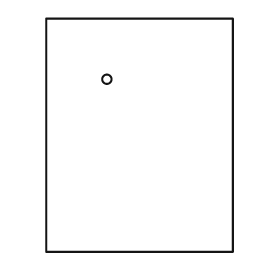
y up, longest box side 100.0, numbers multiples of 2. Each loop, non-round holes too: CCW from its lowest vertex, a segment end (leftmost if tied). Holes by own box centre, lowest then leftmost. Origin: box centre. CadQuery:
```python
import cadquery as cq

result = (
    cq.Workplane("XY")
    .moveTo(-40.0, -50.0)
    .lineTo(40.0, -50.0)
    .lineTo(40.0, 50.0)
    .lineTo(-40.0, 50.0)
    .close()
    .moveTo(-14.0, 24.0)
    .circle(2.0)
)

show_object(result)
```